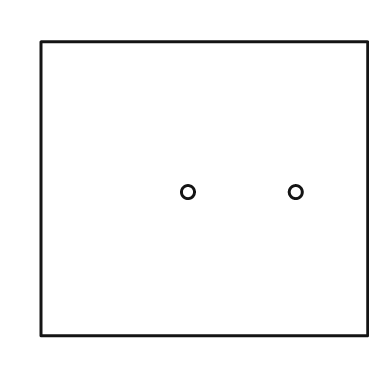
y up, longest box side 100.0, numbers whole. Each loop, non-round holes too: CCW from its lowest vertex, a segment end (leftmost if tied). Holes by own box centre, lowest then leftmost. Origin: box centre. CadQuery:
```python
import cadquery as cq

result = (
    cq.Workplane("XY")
    .moveTo(-50.0, -45.0)
    .lineTo(50.0, -45.0)
    .lineTo(50.0, 45.0)
    .lineTo(-50.0, 45.0)
    .close()
    .moveTo(-5.0, -1.0)
    .circle(2.0)
    .moveTo(28.0, -1.0)
    .circle(2.0)
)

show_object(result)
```